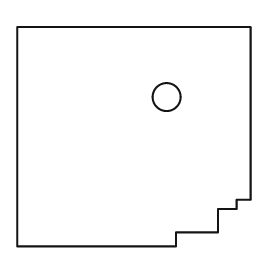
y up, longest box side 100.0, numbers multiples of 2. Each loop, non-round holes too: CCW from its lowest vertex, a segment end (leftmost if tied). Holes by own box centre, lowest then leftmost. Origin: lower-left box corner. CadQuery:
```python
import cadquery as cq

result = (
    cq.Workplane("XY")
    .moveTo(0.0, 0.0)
    .lineTo(68.0, 0.0)
    .lineTo(68.0, 6.0)
    .lineTo(86.0, 6.0)
    .lineTo(86.0, 16.0)
    .lineTo(94.0, 16.0)
    .lineTo(94.0, 20.0)
    .lineTo(100.0, 20.0)
    .lineTo(100.0, 94.0)
    .lineTo(0.0, 94.0)
    .close()
    .moveTo(64.0, 64.0)
    .circle(6.0)
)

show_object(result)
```